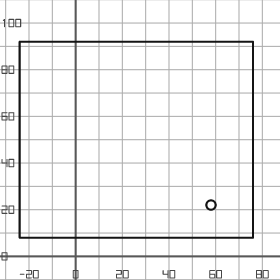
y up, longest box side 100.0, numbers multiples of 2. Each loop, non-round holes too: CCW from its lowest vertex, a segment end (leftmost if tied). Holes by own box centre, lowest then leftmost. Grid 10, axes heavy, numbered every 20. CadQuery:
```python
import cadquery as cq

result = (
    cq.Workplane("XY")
    .moveTo(-24.0, 8.0)
    .lineTo(76.0, 8.0)
    .lineTo(76.0, 92.0)
    .lineTo(-24.0, 92.0)
    .close()
    .moveTo(58.0, 22.0)
    .circle(2.0)
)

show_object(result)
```